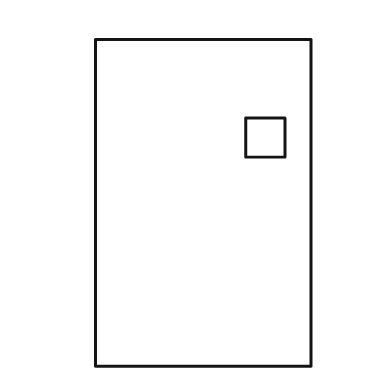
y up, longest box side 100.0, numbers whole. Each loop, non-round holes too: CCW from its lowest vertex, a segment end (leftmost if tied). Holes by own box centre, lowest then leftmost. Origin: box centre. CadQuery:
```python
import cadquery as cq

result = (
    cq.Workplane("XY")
    .moveTo(-33.0, -50.0)
    .lineTo(33.0, -50.0)
    .lineTo(33.0, 50.0)
    .lineTo(-33.0, 50.0)
    .close()
    .moveTo(13.0, 14.0)
    .lineTo(25.0, 14.0)
    .lineTo(25.0, 26.0)
    .lineTo(13.0, 26.0)
    .close()
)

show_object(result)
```